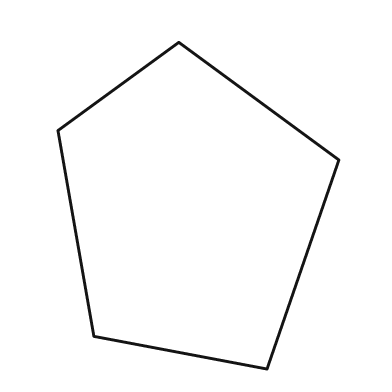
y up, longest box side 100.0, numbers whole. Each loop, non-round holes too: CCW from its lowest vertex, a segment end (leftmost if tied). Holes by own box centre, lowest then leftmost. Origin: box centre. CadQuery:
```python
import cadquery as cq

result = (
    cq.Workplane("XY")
    .moveTo(21.0, -50.0)
    .lineTo(43.0, 14.0)
    .lineTo(-6.0, 50.0)
    .lineTo(-43.0, 23.0)
    .lineTo(-32.0, -40.0)
    .close()
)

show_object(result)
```